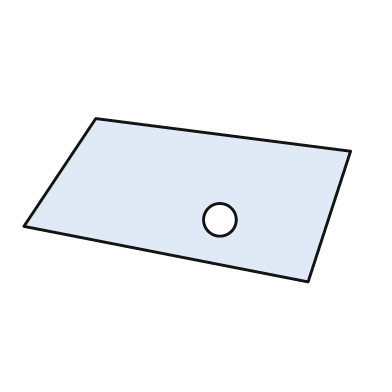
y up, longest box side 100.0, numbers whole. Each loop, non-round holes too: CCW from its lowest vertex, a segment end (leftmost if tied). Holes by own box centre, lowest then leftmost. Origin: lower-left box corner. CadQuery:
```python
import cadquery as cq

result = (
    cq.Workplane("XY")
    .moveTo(87.0, 0.0)
    .lineTo(100.0, 40.0)
    .lineTo(22.0, 50.0)
    .lineTo(0.0, 17.0)
    .close()
    .moveTo(60.0, 19.0)
    .circle(5.0)
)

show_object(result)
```